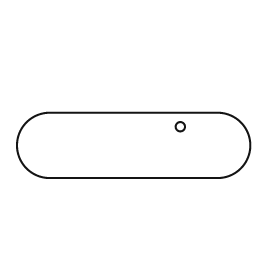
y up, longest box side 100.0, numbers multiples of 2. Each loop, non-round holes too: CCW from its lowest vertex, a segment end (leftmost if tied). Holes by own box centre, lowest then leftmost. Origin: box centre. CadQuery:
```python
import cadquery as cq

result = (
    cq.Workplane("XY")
    .moveTo(-36.0, -14.0)
    .lineTo(36.0, -14.0)
    .threePointArc((50.0, 0.0), (36.0, 14.0))
    .lineTo(-36.0, 14.0)
    .threePointArc((-50.0, 0.0), (-36.0, -14.0))
    .close()
    .moveTo(20.0, 8.0)
    .circle(2.0)
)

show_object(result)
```